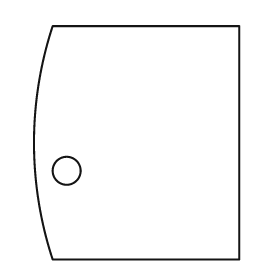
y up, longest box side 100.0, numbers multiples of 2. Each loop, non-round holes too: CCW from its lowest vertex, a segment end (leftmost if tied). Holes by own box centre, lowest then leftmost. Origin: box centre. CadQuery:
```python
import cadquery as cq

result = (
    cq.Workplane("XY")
    .moveTo(-36.0, -50.0)
    .lineTo(44.0, -50.0)
    .lineTo(44.0, 50.0)
    .lineTo(-36.0, 50.0)
    .threePointArc((-44.0, 0.0), (-36.0, -50.0))
    .close()
    .moveTo(-30.0, -12.0)
    .circle(6.0)
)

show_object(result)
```